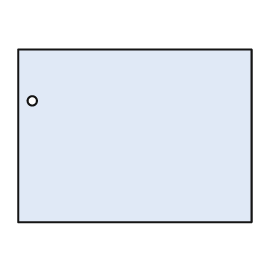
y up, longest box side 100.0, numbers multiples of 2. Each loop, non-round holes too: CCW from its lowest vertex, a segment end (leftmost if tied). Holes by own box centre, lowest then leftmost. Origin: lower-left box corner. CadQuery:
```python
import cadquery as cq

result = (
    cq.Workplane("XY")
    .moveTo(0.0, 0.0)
    .lineTo(100.0, 0.0)
    .lineTo(100.0, 74.0)
    .lineTo(0.0, 74.0)
    .close()
    .moveTo(6.0, 52.0)
    .circle(2.0)
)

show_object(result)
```